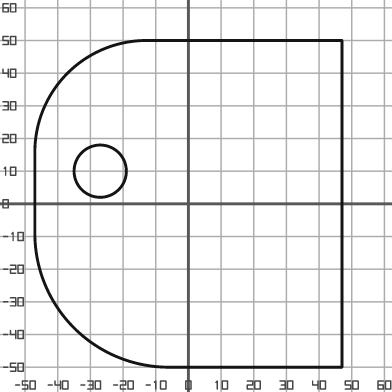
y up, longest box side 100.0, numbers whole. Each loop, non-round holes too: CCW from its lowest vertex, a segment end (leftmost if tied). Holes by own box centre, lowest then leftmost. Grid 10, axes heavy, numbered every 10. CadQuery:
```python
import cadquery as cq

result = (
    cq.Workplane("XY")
    .moveTo(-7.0, -50.0)
    .lineTo(47.0, -50.0)
    .lineTo(47.0, 50.0)
    .lineTo(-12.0, 50.0)
    .threePointArc((-37.0, 40.0), (-47.0, 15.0))
    .lineTo(-47.0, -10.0)
    .threePointArc((-35.0, -38.0), (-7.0, -50.0))
    .close()
    .moveTo(-27.0, 10.0)
    .circle(8.0)
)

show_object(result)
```